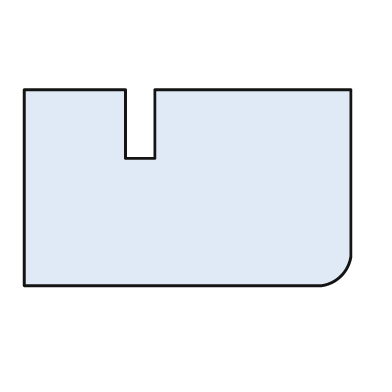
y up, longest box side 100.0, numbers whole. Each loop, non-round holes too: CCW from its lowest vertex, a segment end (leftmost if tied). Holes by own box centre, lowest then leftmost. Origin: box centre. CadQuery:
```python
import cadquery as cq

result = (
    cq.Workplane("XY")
    .moveTo(-50.0, -30.0)
    .lineTo(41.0, -30.0)
    .threePointArc((47.0, -27.0), (50.0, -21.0))
    .lineTo(50.0, 30.0)
    .lineTo(-10.0, 30.0)
    .lineTo(-10.0, 9.0)
    .lineTo(-19.0, 9.0)
    .lineTo(-19.0, 30.0)
    .lineTo(-50.0, 30.0)
    .close()
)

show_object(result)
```